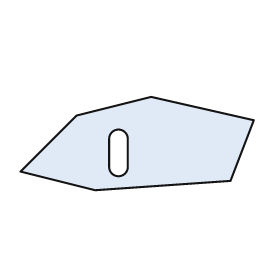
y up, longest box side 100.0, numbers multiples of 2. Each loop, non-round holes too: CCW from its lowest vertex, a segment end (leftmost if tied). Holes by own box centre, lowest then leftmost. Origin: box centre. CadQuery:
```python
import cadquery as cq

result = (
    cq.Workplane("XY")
    .moveTo(-18.0, -20.0)
    .lineTo(40.0, -16.0)
    .lineTo(50.0, 10.0)
    .lineTo(6.0, 20.0)
    .lineTo(-26.0, 12.0)
    .lineTo(-50.0, -12.0)
    .close()
    .moveTo(-12.0, -10.0)
    .threePointArc((-8.0, -14.0), (-4.0, -10.0))
    .lineTo(-4.0, 2.0)
    .threePointArc((-8.0, 6.0), (-12.0, 2.0))
    .close()
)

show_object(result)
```